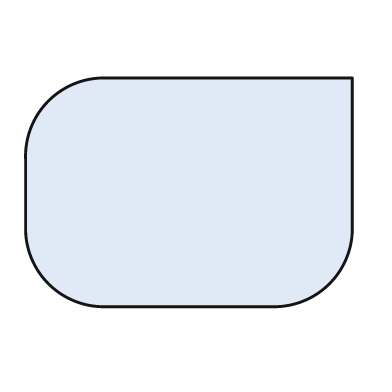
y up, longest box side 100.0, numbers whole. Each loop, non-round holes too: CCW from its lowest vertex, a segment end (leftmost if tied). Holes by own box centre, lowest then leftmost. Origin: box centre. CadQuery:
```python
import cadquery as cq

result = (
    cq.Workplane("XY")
    .moveTo(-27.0, -35.0)
    .lineTo(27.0, -35.0)
    .threePointArc((43.0, -28.0), (50.0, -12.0))
    .lineTo(50.0, 35.0)
    .lineTo(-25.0, 35.0)
    .threePointArc((-43.0, 28.0), (-50.0, 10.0))
    .lineTo(-50.0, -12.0)
    .threePointArc((-43.0, -28.0), (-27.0, -35.0))
    .close()
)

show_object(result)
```